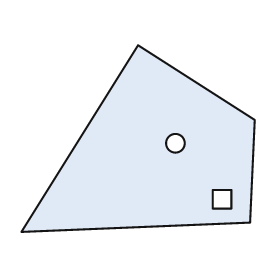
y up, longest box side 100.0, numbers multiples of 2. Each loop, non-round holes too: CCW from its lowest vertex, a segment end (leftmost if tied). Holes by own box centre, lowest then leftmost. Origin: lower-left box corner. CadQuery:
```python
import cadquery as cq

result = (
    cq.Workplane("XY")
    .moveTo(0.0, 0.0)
    .lineTo(98.0, 4.0)
    .lineTo(100.0, 48.0)
    .lineTo(50.0, 80.0)
    .close()
    .moveTo(82.0, 10.0)
    .lineTo(90.0, 10.0)
    .lineTo(90.0, 18.0)
    .lineTo(82.0, 18.0)
    .close()
    .moveTo(66.0, 38.0)
    .circle(4.0)
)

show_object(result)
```